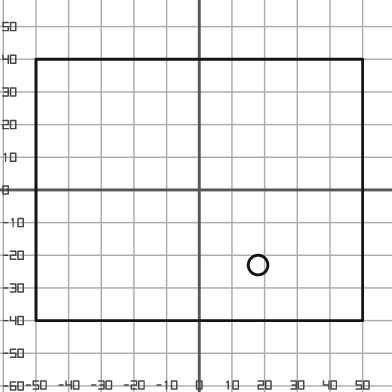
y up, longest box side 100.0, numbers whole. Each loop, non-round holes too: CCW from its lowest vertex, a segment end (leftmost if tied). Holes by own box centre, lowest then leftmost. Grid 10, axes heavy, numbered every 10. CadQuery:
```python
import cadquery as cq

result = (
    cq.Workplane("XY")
    .moveTo(-50.0, -40.0)
    .lineTo(50.0, -40.0)
    .lineTo(50.0, 40.0)
    .lineTo(-50.0, 40.0)
    .close()
    .moveTo(18.0, -23.0)
    .circle(3.0)
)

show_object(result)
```